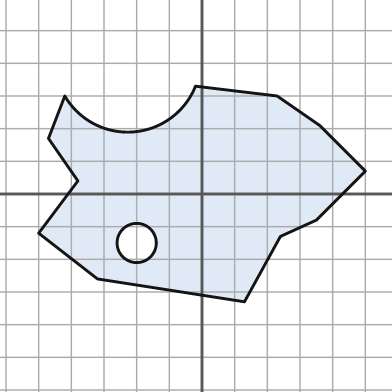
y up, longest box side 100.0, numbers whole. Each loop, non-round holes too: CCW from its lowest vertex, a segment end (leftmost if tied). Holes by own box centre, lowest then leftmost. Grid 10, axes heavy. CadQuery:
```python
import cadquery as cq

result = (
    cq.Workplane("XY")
    .moveTo(13.0, -33.0)
    .lineTo(24.0, -13.0)
    .lineTo(35.0, -8.0)
    .lineTo(50.0, 7.0)
    .lineTo(36.0, 21.0)
    .lineTo(23.0, 30.0)
    .lineTo(-2.0, 33.0)
    .threePointArc((-21.0, 19.0), (-42.0, 30.0))
    .lineTo(-47.0, 17.0)
    .lineTo(-38.0, 4.0)
    .lineTo(-50.0, -12.0)
    .lineTo(-32.0, -26.0)
    .close()
    .moveTo(-20.0, -15.0)
    .circle(6.0)
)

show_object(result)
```